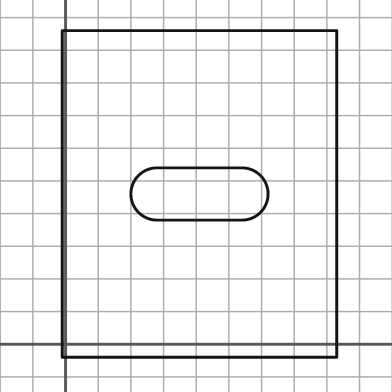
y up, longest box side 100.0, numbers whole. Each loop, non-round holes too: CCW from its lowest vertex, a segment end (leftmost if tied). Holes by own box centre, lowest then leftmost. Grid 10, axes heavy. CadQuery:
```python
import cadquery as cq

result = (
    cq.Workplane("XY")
    .moveTo(-1.0, -4.0)
    .lineTo(83.0, -4.0)
    .lineTo(83.0, 96.0)
    .lineTo(-1.0, 96.0)
    .close()
    .moveTo(28.0, 38.0)
    .lineTo(54.0, 38.0)
    .threePointArc((62.0, 46.0), (54.0, 54.0))
    .lineTo(28.0, 54.0)
    .threePointArc((20.0, 46.0), (28.0, 38.0))
    .close()
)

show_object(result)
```